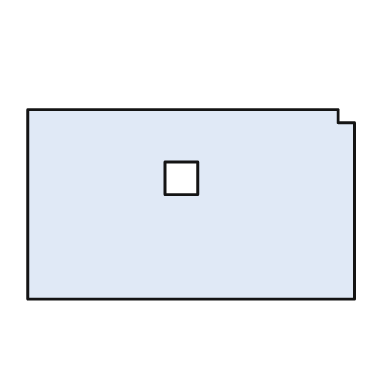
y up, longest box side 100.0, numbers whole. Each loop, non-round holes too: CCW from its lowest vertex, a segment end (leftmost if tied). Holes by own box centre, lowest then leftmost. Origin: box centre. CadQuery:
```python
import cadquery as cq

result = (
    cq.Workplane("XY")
    .moveTo(-50.0, -29.0)
    .lineTo(50.0, -29.0)
    .lineTo(50.0, 25.0)
    .lineTo(45.0, 25.0)
    .lineTo(45.0, 29.0)
    .lineTo(-50.0, 29.0)
    .close()
    .moveTo(-8.0, 3.0)
    .lineTo(2.0, 3.0)
    .lineTo(2.0, 13.0)
    .lineTo(-8.0, 13.0)
    .close()
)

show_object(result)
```